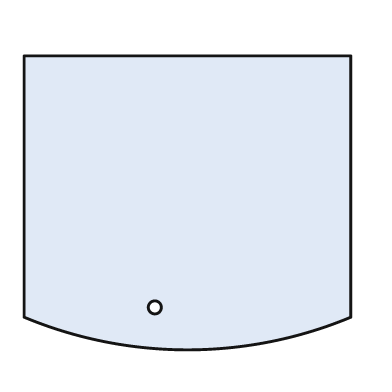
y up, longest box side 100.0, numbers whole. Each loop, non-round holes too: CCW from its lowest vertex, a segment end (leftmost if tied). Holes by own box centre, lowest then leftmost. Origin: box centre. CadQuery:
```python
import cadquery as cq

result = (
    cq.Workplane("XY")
    .moveTo(-50.0, -35.0)
    .threePointArc((0.0, -45.0), (50.0, -35.0))
    .lineTo(50.0, 45.0)
    .lineTo(-50.0, 45.0)
    .close()
    .moveTo(-10.0, -32.0)
    .circle(2.0)
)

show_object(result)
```